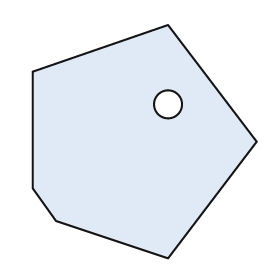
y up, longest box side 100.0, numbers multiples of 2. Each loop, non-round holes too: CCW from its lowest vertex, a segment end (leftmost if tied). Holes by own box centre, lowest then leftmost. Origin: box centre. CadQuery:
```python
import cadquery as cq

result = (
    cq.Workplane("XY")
    .moveTo(10.0, -50.0)
    .lineTo(48.0, 0.0)
    .lineTo(10.0, 50.0)
    .lineTo(-48.0, 30.0)
    .lineTo(-48.0, -20.0)
    .lineTo(-38.0, -34.0)
    .close()
    .moveTo(10.0, 16.0)
    .circle(6.0)
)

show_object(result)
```